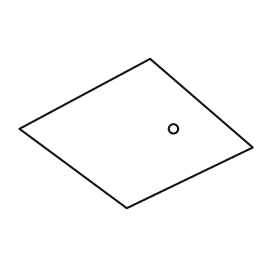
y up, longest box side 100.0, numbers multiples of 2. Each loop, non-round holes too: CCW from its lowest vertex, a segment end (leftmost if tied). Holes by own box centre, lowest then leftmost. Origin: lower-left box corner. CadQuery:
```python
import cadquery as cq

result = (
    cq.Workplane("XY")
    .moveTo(46.0, 0.0)
    .lineTo(100.0, 26.0)
    .lineTo(56.0, 64.0)
    .lineTo(0.0, 34.0)
    .close()
    .moveTo(66.0, 34.0)
    .circle(2.0)
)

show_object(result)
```